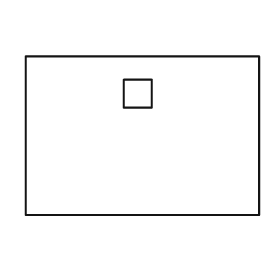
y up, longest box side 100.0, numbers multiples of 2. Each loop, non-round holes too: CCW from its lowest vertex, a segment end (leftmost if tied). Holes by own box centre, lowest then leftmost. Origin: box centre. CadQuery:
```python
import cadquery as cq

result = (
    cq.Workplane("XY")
    .moveTo(-50.0, -34.0)
    .lineTo(50.0, -34.0)
    .lineTo(50.0, 34.0)
    .lineTo(-50.0, 34.0)
    .close()
    .moveTo(-8.0, 12.0)
    .lineTo(4.0, 12.0)
    .lineTo(4.0, 24.0)
    .lineTo(-8.0, 24.0)
    .close()
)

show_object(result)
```